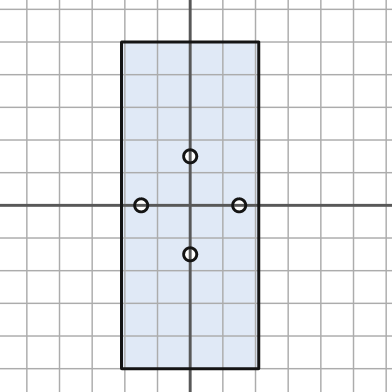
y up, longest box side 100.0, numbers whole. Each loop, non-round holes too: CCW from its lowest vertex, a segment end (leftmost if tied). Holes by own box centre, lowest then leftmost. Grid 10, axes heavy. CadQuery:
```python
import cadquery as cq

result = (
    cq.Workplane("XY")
    .moveTo(-21.0, -50.0)
    .lineTo(21.0, -50.0)
    .lineTo(21.0, 50.0)
    .lineTo(-21.0, 50.0)
    .close()
    .moveTo(0.0, -15.0)
    .circle(2.0)
    .moveTo(-15.0, 0.0)
    .circle(2.0)
    .moveTo(15.0, 0.0)
    .circle(2.0)
    .moveTo(0.0, 15.0)
    .circle(2.0)
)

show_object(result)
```